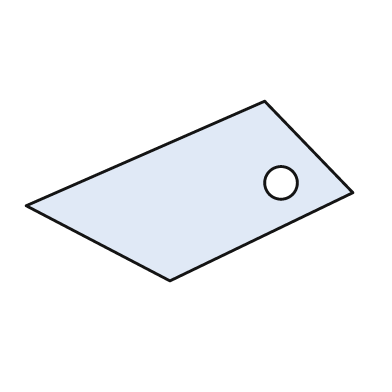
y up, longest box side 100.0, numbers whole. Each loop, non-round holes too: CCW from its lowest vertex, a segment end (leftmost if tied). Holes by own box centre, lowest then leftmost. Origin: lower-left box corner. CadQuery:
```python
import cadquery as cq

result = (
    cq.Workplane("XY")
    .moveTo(44.0, 0.0)
    .lineTo(100.0, 27.0)
    .lineTo(73.0, 55.0)
    .lineTo(0.0, 23.0)
    .close()
    .moveTo(78.0, 30.0)
    .circle(5.0)
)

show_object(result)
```